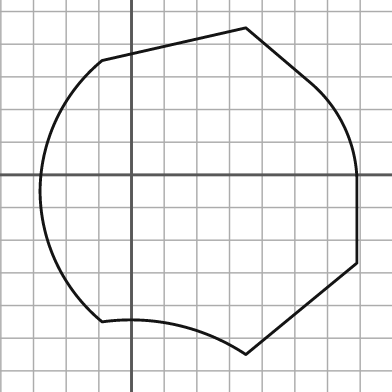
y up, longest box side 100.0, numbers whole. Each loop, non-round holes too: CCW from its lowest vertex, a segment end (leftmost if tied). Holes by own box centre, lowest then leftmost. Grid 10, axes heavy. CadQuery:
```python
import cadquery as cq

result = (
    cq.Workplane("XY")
    .moveTo(35.0, -55.0)
    .lineTo(69.0, -27.0)
    .lineTo(69.0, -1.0)
    .threePointArc((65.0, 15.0), (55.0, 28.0))
    .lineTo(35.0, 45.0)
    .lineTo(-9.0, 35.0)
    .threePointArc((-23.0, 17.0), (-28.0, -5.0))
    .threePointArc((-23.0, -27.0), (-9.0, -45.0))
    .threePointArc((14.0, -46.0), (35.0, -55.0))
    .close()
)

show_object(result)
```